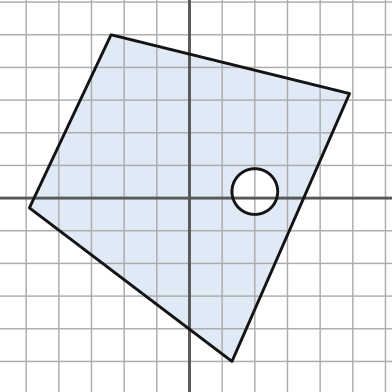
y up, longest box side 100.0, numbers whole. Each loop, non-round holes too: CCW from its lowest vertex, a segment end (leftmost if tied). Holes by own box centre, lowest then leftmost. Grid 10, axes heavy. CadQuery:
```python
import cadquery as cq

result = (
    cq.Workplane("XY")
    .moveTo(13.0, -50.0)
    .lineTo(49.0, 32.0)
    .lineTo(-24.0, 50.0)
    .lineTo(-49.0, -3.0)
    .close()
    .moveTo(20.0, 2.0)
    .circle(7.0)
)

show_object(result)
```